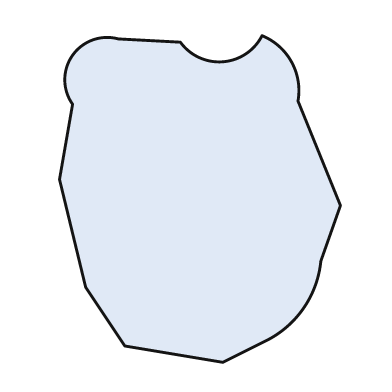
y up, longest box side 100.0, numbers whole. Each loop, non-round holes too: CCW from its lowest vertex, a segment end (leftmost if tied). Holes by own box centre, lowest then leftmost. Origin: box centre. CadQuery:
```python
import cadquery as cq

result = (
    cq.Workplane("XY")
    .moveTo(7.0, -50.0)
    .lineTo(21.0, -43.0)
    .threePointArc((32.0, -33.0), (37.0, -19.0))
    .lineTo(43.0, -2.0)
    .lineTo(30.0, 30.0)
    .threePointArc((28.0, 42.0), (19.0, 50.0))
    .threePointArc((7.0, 42.0), (-6.0, 48.0))
    .lineTo(-25.0, 49.0)
    .threePointArc((-39.0, 44.0), (-39.0, 29.0))
    .lineTo(-43.0, 6.0)
    .lineTo(-35.0, -27.0)
    .lineTo(-23.0, -45.0)
    .close()
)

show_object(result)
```